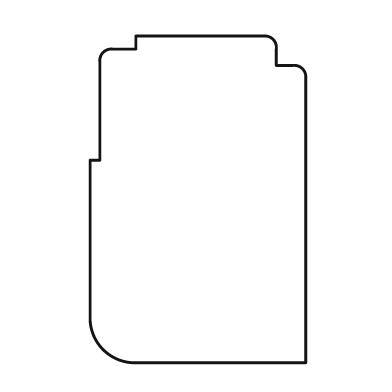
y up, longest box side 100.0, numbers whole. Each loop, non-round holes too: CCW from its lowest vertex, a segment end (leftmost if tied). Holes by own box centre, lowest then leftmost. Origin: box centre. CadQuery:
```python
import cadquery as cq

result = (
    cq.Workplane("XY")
    .moveTo(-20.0, -50.0)
    .lineTo(33.0, -50.0)
    .lineTo(33.0, 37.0)
    .threePointArc((32.0, 40.0), (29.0, 41.0))
    .lineTo(24.0, 41.0)
    .lineTo(24.0, 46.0)
    .threePointArc((23.0, 49.0), (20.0, 50.0))
    .lineTo(-19.0, 50.0)
    .lineTo(-19.0, 46.0)
    .lineTo(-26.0, 46.0)
    .threePointArc((-29.0, 45.0), (-30.0, 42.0))
    .lineTo(-30.0, 12.0)
    .lineTo(-33.0, 12.0)
    .lineTo(-33.0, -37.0)
    .threePointArc((-29.0, -46.0), (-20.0, -50.0))
    .close()
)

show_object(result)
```